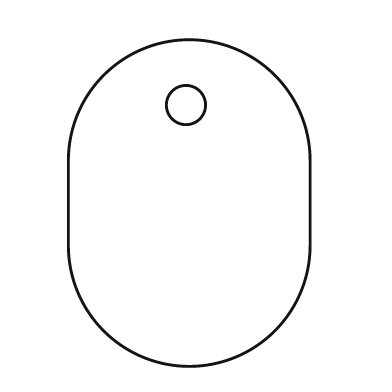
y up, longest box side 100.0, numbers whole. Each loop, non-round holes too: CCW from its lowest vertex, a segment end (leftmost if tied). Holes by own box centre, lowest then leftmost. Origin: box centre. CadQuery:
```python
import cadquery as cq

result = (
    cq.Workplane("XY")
    .moveTo(-37.0, -13.0)
    .threePointArc((0.0, -50.0), (37.0, -13.0))
    .lineTo(37.0, 13.0)
    .threePointArc((0.0, 50.0), (-37.0, 13.0))
    .close()
    .moveTo(-1.0, 30.0)
    .circle(6.0)
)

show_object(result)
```